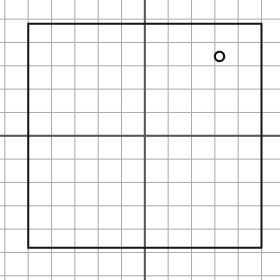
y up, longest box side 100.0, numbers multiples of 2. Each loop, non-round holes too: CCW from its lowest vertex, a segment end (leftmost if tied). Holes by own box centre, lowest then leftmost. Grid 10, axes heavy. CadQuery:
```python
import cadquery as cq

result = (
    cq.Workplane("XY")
    .moveTo(-50.0, -48.0)
    .lineTo(50.0, -48.0)
    .lineTo(50.0, 48.0)
    .lineTo(-50.0, 48.0)
    .close()
    .moveTo(32.0, 34.0)
    .circle(2.0)
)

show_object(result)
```